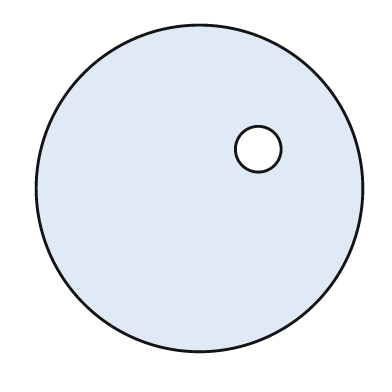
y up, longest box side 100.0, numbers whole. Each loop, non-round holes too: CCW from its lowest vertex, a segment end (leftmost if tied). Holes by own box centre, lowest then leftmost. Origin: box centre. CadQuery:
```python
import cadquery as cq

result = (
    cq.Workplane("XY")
    .moveTo(0.0, 0.0)
    .circle(50.0)
    .moveTo(18.0, 12.0)
    .circle(7.0)
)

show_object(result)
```